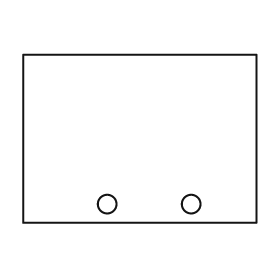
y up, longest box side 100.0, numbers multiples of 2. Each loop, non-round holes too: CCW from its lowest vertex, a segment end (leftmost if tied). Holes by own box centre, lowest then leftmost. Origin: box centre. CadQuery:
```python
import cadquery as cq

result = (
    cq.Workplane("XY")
    .moveTo(-50.0, -36.0)
    .lineTo(50.0, -36.0)
    .lineTo(50.0, 36.0)
    .lineTo(-50.0, 36.0)
    .close()
    .moveTo(-14.0, -28.0)
    .circle(4.0)
    .moveTo(22.0, -28.0)
    .circle(4.0)
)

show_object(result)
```